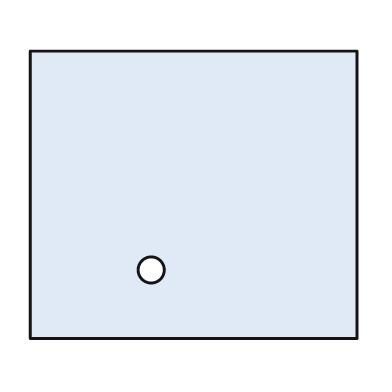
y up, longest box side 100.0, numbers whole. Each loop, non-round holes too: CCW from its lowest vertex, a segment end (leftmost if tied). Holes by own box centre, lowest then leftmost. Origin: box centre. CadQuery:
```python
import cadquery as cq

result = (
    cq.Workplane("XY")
    .moveTo(-50.0, -44.0)
    .lineTo(50.0, -44.0)
    .lineTo(50.0, 44.0)
    .lineTo(-50.0, 44.0)
    .close()
    .moveTo(-13.0, -23.0)
    .circle(4.0)
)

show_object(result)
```